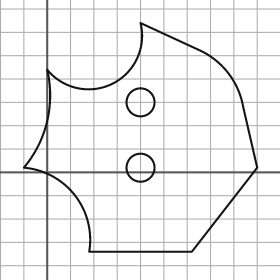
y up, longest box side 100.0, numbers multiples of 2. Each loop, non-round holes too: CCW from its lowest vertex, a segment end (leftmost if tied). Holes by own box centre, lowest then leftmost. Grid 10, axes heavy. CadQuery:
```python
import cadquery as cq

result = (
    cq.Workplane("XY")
    .moveTo(18.0, -34.0)
    .lineTo(62.0, -34.0)
    .lineTo(90.0, 2.0)
    .lineTo(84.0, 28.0)
    .threePointArc((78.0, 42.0), (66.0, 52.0))
    .lineTo(40.0, 64.0)
    .threePointArc((28.0, 38.0), (0.0, 44.0))
    .threePointArc((0.0, 22.0), (-10.0, 2.0))
    .threePointArc((12.0, -10.0), (18.0, -34.0))
    .close()
    .moveTo(40.0, 2.0)
    .circle(6.0)
    .moveTo(40.0, 30.0)
    .circle(6.0)
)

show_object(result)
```